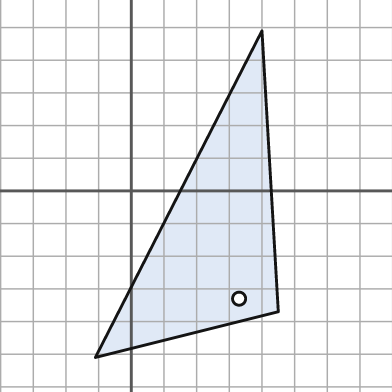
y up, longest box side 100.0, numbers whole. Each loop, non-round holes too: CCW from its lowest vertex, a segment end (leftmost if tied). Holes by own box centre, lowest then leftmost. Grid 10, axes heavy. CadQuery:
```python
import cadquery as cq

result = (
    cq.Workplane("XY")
    .moveTo(-11.0, -51.0)
    .lineTo(45.0, -37.0)
    .lineTo(40.0, 49.0)
    .close()
    .moveTo(33.0, -33.0)
    .circle(2.0)
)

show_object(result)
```